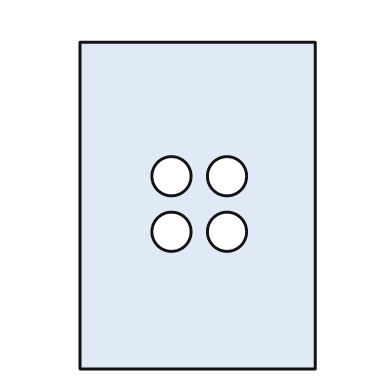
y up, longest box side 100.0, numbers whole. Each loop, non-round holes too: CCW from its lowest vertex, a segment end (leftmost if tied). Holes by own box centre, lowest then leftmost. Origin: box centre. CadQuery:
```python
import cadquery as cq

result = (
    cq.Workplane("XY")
    .moveTo(-36.0, -50.0)
    .lineTo(36.0, -50.0)
    .lineTo(36.0, 50.0)
    .lineTo(-36.0, 50.0)
    .close()
    .moveTo(-8.0, -8.0)
    .circle(6.0)
    .moveTo(9.0, -8.0)
    .circle(6.0)
    .moveTo(-8.0, 9.0)
    .circle(6.0)
    .moveTo(9.0, 9.0)
    .circle(6.0)
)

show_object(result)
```